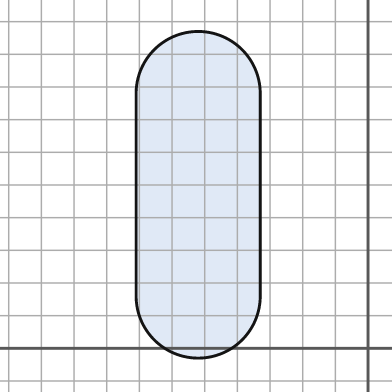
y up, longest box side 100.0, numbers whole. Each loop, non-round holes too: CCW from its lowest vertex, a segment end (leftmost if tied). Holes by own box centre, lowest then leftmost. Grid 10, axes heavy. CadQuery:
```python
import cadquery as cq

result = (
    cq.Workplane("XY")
    .moveTo(-71.0, 16.0)
    .threePointArc((-52.0, -3.0), (-33.0, 16.0))
    .lineTo(-33.0, 78.0)
    .threePointArc((-52.0, 97.0), (-71.0, 78.0))
    .close()
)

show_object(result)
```